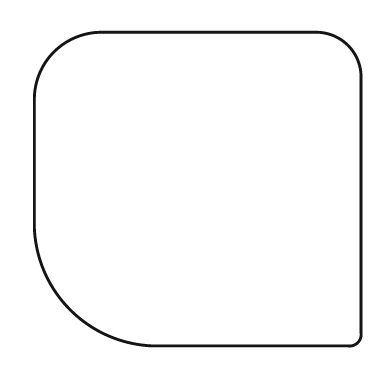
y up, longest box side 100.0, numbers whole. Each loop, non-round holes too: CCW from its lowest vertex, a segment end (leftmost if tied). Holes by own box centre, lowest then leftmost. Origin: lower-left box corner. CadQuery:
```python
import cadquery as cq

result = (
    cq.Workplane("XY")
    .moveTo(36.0, 0.0)
    .lineTo(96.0, 0.0)
    .threePointArc((99.0, 1.0), (100.0, 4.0))
    .lineTo(100.0, 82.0)
    .threePointArc((96.0, 92.0), (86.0, 96.0))
    .lineTo(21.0, 96.0)
    .threePointArc((6.0, 90.0), (0.0, 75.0))
    .lineTo(0.0, 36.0)
    .threePointArc((11.0, 11.0), (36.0, 0.0))
    .close()
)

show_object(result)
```